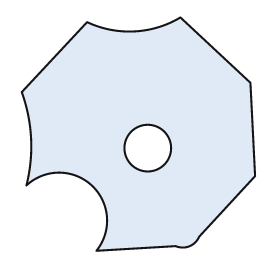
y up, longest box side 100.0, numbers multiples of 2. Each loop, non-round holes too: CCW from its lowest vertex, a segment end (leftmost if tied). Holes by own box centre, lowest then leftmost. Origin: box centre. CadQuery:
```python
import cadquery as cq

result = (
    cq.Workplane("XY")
    .moveTo(-18.0, -50.0)
    .lineTo(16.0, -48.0)
    .threePointArc((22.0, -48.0), (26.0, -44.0))
    .lineTo(50.0, -18.0)
    .lineTo(48.0, 22.0)
    .lineTo(18.0, 50.0)
    .threePointArc((-2.0, 44.0), (-22.0, 48.0))
    .lineTo(-50.0, 18.0)
    .threePointArc((-46.0, -2.0), (-48.0, -22.0))
    .threePointArc((-20.0, -22.0), (-18.0, -50.0))
    .close()
    .moveTo(4.0, -6.0)
    .circle(10.0)
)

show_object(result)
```